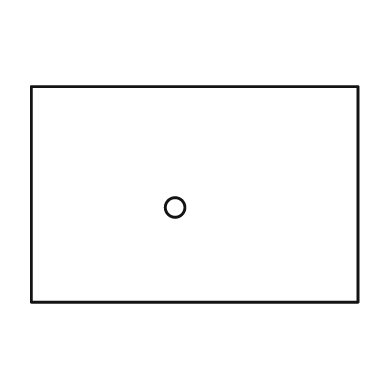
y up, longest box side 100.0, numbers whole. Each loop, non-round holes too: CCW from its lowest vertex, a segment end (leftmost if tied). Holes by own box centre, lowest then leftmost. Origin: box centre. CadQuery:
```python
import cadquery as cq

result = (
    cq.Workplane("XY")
    .moveTo(-50.0, -33.0)
    .lineTo(50.0, -33.0)
    .lineTo(50.0, 33.0)
    .lineTo(-50.0, 33.0)
    .close()
    .moveTo(-6.0, -4.0)
    .circle(3.0)
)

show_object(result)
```